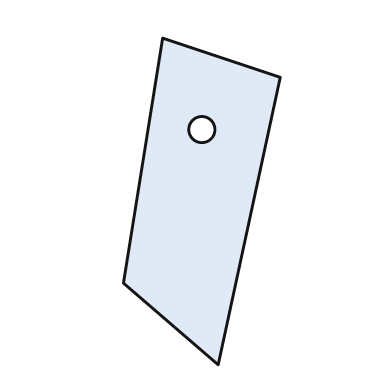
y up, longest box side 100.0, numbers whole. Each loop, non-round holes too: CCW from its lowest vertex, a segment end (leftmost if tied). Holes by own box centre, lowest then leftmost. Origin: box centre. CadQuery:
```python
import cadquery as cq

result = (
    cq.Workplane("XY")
    .moveTo(5.0, -50.0)
    .lineTo(24.0, 38.0)
    .lineTo(-12.0, 50.0)
    .lineTo(-24.0, -25.0)
    .close()
    .moveTo(0.0, 22.0)
    .circle(4.0)
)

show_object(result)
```